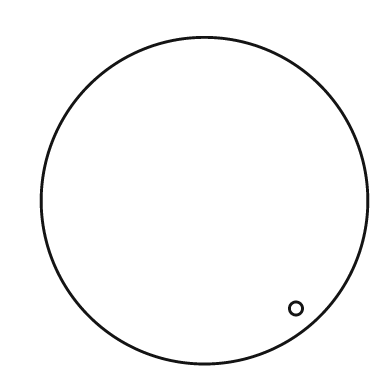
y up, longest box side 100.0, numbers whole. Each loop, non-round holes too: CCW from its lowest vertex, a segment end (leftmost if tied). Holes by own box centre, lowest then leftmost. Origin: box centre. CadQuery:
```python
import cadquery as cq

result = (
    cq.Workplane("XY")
    .moveTo(0.0, 0.0)
    .circle(50.0)
    .moveTo(28.0, -33.0)
    .circle(2.0)
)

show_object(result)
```